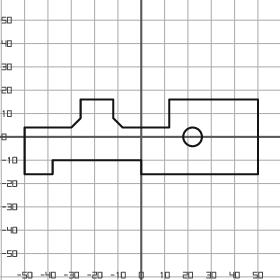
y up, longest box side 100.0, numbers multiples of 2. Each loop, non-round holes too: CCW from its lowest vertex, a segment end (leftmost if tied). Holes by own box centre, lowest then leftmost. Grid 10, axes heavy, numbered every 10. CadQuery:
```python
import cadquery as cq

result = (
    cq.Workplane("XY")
    .moveTo(-50.0, -16.0)
    .lineTo(-38.0, -16.0)
    .lineTo(-38.0, -10.0)
    .lineTo(0.0, -10.0)
    .lineTo(0.0, -16.0)
    .lineTo(50.0, -16.0)
    .lineTo(50.0, 16.0)
    .lineTo(12.0, 16.0)
    .lineTo(12.0, 4.0)
    .lineTo(-8.0, 4.0)
    .lineTo(-12.0, 8.0)
    .lineTo(-12.0, 16.0)
    .lineTo(-26.0, 16.0)
    .lineTo(-26.0, 8.0)
    .lineTo(-30.0, 4.0)
    .lineTo(-50.0, 4.0)
    .close()
    .moveTo(22.0, 0.0)
    .circle(4.0)
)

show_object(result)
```